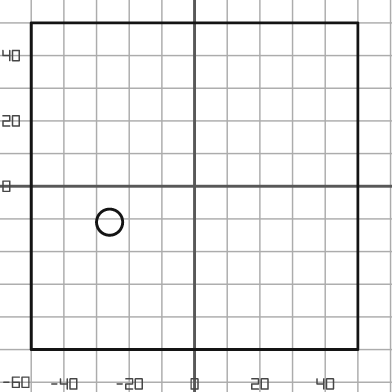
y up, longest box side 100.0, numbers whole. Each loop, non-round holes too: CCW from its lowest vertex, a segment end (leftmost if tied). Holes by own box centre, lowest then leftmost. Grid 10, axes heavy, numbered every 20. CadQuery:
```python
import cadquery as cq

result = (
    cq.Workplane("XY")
    .moveTo(-50.0, -50.0)
    .lineTo(50.0, -50.0)
    .lineTo(50.0, 50.0)
    .lineTo(-50.0, 50.0)
    .close()
    .moveTo(-26.0, -11.0)
    .circle(4.0)
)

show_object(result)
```